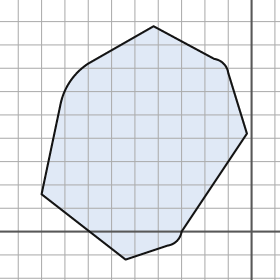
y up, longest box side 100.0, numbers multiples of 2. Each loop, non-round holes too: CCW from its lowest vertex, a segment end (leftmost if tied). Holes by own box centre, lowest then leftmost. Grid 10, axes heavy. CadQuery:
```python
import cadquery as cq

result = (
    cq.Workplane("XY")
    .moveTo(-54.0, -12.0)
    .lineTo(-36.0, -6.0)
    .threePointArc((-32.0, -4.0), (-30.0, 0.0))
    .lineTo(-2.0, 42.0)
    .lineTo(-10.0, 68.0)
    .threePointArc((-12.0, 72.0), (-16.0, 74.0))
    .lineTo(-42.0, 88.0)
    .lineTo(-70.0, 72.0)
    .threePointArc((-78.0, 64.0), (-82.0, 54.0))
    .lineTo(-90.0, 16.0)
    .close()
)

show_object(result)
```